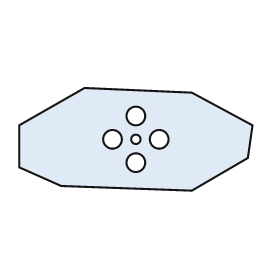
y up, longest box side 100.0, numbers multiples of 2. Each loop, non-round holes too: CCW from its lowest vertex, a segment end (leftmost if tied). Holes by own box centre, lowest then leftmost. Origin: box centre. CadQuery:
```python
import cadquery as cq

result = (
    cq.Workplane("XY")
    .moveTo(24.0, -22.0)
    .lineTo(48.0, -8.0)
    .lineTo(50.0, 6.0)
    .lineTo(24.0, 20.0)
    .lineTo(-22.0, 22.0)
    .lineTo(-50.0, 6.0)
    .lineTo(-50.0, -12.0)
    .lineTo(-32.0, -20.0)
    .close()
    .moveTo(0.0, -10.0)
    .circle(4.0)
    .moveTo(-10.0, 0.0)
    .circle(4.0)
    .moveTo(0.0, 0.0)
    .circle(2.0)
    .moveTo(10.0, 0.0)
    .circle(4.0)
    .moveTo(0.0, 10.0)
    .circle(4.0)
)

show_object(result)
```